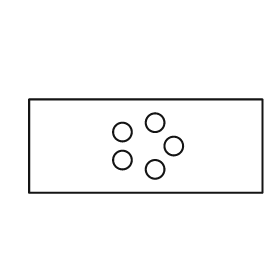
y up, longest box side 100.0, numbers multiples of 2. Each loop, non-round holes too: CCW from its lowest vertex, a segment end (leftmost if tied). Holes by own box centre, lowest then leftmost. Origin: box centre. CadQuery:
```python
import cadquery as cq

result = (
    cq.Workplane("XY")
    .moveTo(-50.0, -20.0)
    .lineTo(50.0, -20.0)
    .lineTo(50.0, 20.0)
    .lineTo(-50.0, 20.0)
    .close()
    .moveTo(4.0, -10.0)
    .circle(4.0)
    .moveTo(-10.0, -6.0)
    .circle(4.0)
    .moveTo(12.0, 0.0)
    .circle(4.0)
    .moveTo(-10.0, 6.0)
    .circle(4.0)
    .moveTo(4.0, 10.0)
    .circle(4.0)
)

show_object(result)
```